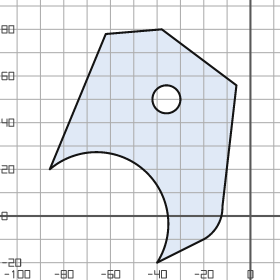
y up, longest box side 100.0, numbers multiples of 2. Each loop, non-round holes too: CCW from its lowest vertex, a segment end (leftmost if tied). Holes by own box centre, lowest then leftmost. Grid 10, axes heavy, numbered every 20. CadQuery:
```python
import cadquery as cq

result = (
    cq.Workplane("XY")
    .moveTo(-40.0, -20.0)
    .lineTo(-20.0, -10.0)
    .threePointArc((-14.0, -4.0), (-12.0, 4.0))
    .lineTo(-6.0, 56.0)
    .lineTo(-38.0, 80.0)
    .lineTo(-62.0, 78.0)
    .lineTo(-86.0, 20.0)
    .threePointArc((-46.0, 20.0), (-40.0, -20.0))
    .close()
    .moveTo(-36.0, 50.0)
    .circle(6.0)
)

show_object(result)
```